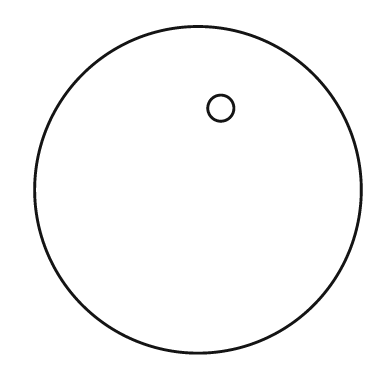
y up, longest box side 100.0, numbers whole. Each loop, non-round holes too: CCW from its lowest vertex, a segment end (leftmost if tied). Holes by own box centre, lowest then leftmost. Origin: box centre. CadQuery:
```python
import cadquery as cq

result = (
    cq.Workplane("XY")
    .moveTo(0.0, 0.0)
    .circle(50.0)
    .moveTo(7.0, 25.0)
    .circle(4.0)
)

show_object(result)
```